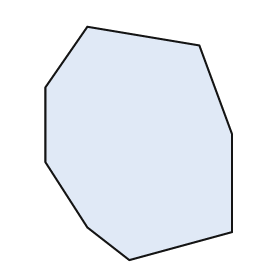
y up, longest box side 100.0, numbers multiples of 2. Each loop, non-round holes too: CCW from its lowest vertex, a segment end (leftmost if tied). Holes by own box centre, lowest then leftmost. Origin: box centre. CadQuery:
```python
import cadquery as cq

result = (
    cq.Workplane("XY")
    .moveTo(-4.0, -50.0)
    .lineTo(40.0, -38.0)
    .lineTo(40.0, 4.0)
    .lineTo(26.0, 42.0)
    .lineTo(-22.0, 50.0)
    .lineTo(-40.0, 24.0)
    .lineTo(-40.0, -8.0)
    .lineTo(-22.0, -36.0)
    .close()
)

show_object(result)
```